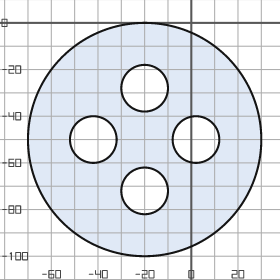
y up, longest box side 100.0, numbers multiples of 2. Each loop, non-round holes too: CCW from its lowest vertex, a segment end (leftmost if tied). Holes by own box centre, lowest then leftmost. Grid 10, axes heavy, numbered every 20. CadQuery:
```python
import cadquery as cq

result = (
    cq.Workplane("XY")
    .moveTo(-20.0, -50.0)
    .circle(50.0)
    .moveTo(-20.0, -72.0)
    .circle(10.0)
    .moveTo(-42.0, -50.0)
    .circle(10.0)
    .moveTo(2.0, -50.0)
    .circle(10.0)
    .moveTo(-20.0, -28.0)
    .circle(10.0)
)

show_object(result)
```